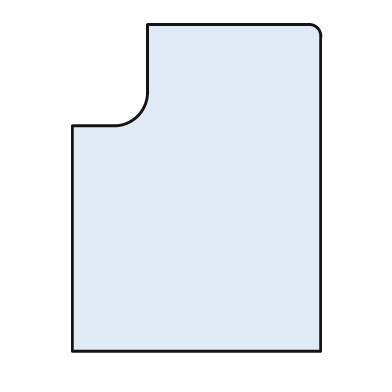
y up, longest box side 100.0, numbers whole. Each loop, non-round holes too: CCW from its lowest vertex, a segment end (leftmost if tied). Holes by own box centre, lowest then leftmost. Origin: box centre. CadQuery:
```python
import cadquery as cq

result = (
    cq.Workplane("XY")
    .moveTo(-38.0, -50.0)
    .lineTo(38.0, -50.0)
    .lineTo(38.0, 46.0)
    .threePointArc((37.0, 49.0), (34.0, 50.0))
    .lineTo(-15.0, 50.0)
    .lineTo(-15.0, 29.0)
    .threePointArc((-18.0, 22.0), (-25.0, 19.0))
    .lineTo(-38.0, 19.0)
    .close()
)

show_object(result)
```